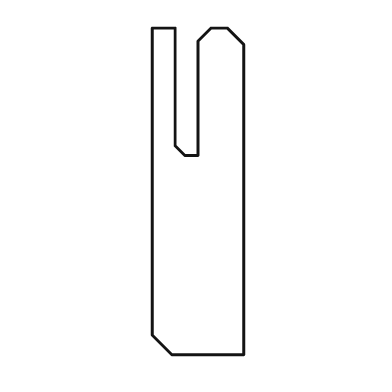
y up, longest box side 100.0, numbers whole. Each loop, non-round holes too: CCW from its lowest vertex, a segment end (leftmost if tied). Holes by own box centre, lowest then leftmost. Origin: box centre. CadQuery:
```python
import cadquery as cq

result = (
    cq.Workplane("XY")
    .moveTo(-8.0, -50.0)
    .lineTo(14.0, -50.0)
    .lineTo(14.0, 45.0)
    .lineTo(9.0, 50.0)
    .lineTo(4.0, 50.0)
    .lineTo(0.0, 46.0)
    .lineTo(0.0, 11.0)
    .lineTo(-4.0, 11.0)
    .lineTo(-7.0, 14.0)
    .lineTo(-7.0, 50.0)
    .lineTo(-14.0, 50.0)
    .lineTo(-14.0, -44.0)
    .close()
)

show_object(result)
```